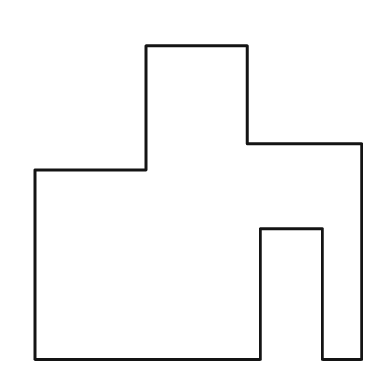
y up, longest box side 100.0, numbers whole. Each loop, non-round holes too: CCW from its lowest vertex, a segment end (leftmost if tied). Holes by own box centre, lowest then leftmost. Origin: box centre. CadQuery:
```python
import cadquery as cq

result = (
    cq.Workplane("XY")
    .moveTo(-50.0, -48.0)
    .lineTo(19.0, -48.0)
    .lineTo(19.0, -8.0)
    .lineTo(38.0, -8.0)
    .lineTo(38.0, -48.0)
    .lineTo(50.0, -48.0)
    .lineTo(50.0, 18.0)
    .lineTo(15.0, 18.0)
    .lineTo(15.0, 48.0)
    .lineTo(-16.0, 48.0)
    .lineTo(-16.0, 10.0)
    .lineTo(-50.0, 10.0)
    .close()
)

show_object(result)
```